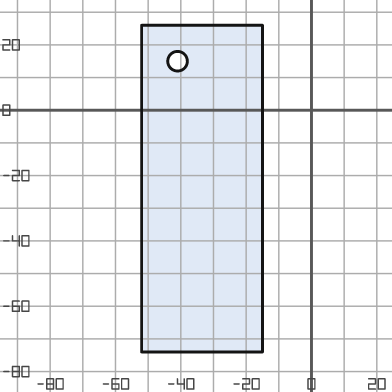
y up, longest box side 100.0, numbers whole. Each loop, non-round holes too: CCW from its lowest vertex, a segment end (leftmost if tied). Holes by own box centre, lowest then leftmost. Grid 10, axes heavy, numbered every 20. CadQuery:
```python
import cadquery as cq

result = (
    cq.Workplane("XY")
    .moveTo(-52.0, -74.0)
    .lineTo(-15.0, -74.0)
    .lineTo(-15.0, 26.0)
    .lineTo(-52.0, 26.0)
    .close()
    .moveTo(-41.0, 15.0)
    .circle(3.0)
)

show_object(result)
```